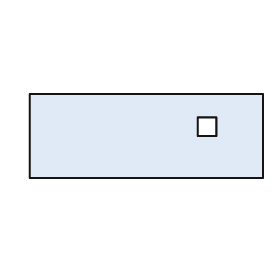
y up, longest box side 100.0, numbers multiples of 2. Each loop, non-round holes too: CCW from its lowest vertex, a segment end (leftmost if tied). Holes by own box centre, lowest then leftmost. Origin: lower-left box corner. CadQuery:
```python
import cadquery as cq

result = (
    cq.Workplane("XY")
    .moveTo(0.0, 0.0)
    .lineTo(100.0, 0.0)
    .lineTo(100.0, 36.0)
    .lineTo(0.0, 36.0)
    .close()
    .moveTo(72.0, 18.0)
    .lineTo(80.0, 18.0)
    .lineTo(80.0, 26.0)
    .lineTo(72.0, 26.0)
    .close()
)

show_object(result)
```